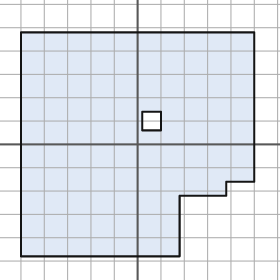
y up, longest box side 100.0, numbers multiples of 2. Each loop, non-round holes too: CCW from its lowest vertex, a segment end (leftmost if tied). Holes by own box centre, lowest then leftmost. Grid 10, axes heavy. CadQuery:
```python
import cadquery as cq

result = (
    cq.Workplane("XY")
    .moveTo(-50.0, -48.0)
    .lineTo(18.0, -48.0)
    .lineTo(18.0, -22.0)
    .lineTo(38.0, -22.0)
    .lineTo(38.0, -16.0)
    .lineTo(50.0, -16.0)
    .lineTo(50.0, 48.0)
    .lineTo(-50.0, 48.0)
    .close()
    .moveTo(2.0, 6.0)
    .lineTo(10.0, 6.0)
    .lineTo(10.0, 14.0)
    .lineTo(2.0, 14.0)
    .close()
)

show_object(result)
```